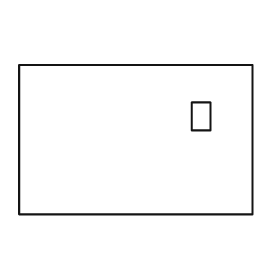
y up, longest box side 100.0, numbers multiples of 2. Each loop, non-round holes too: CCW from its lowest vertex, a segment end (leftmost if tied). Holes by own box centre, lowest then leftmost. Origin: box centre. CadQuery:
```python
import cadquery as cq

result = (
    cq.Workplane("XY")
    .moveTo(-50.0, -32.0)
    .lineTo(50.0, -32.0)
    .lineTo(50.0, 32.0)
    .lineTo(-50.0, 32.0)
    .close()
    .moveTo(24.0, 4.0)
    .lineTo(32.0, 4.0)
    .lineTo(32.0, 16.0)
    .lineTo(24.0, 16.0)
    .close()
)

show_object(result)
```